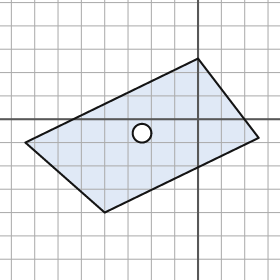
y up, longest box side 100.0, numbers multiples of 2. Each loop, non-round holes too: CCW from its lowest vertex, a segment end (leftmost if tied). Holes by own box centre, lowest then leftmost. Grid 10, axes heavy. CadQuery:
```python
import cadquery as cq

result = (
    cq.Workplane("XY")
    .moveTo(-40.0, -40.0)
    .lineTo(26.0, -8.0)
    .lineTo(0.0, 26.0)
    .lineTo(-74.0, -10.0)
    .close()
    .moveTo(-24.0, -6.0)
    .circle(4.0)
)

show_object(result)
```